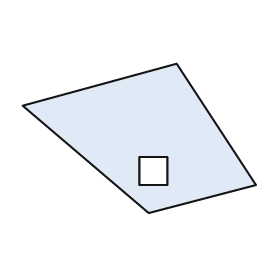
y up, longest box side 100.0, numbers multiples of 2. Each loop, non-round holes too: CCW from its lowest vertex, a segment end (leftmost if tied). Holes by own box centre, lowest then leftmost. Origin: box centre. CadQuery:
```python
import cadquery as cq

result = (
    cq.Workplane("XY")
    .moveTo(4.0, -32.0)
    .lineTo(50.0, -20.0)
    .lineTo(16.0, 32.0)
    .lineTo(-50.0, 14.0)
    .close()
    .moveTo(0.0, -20.0)
    .lineTo(12.0, -20.0)
    .lineTo(12.0, -8.0)
    .lineTo(0.0, -8.0)
    .close()
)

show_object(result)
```